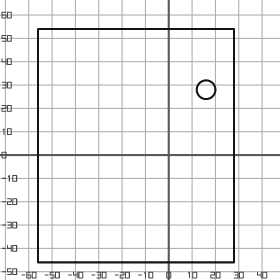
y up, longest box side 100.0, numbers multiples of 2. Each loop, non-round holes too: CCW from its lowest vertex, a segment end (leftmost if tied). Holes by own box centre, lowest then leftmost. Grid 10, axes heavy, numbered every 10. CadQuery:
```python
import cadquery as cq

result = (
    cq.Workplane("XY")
    .moveTo(-56.0, -46.0)
    .lineTo(28.0, -46.0)
    .lineTo(28.0, 54.0)
    .lineTo(-56.0, 54.0)
    .close()
    .moveTo(16.0, 28.0)
    .circle(4.0)
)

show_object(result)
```